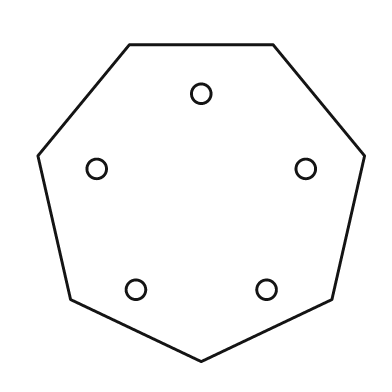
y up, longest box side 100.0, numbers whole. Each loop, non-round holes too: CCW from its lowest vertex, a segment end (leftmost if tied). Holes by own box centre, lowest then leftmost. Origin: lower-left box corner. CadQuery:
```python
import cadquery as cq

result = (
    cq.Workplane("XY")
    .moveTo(50.0, 0.0)
    .lineTo(90.0, 19.0)
    .lineTo(100.0, 63.0)
    .lineTo(72.0, 97.0)
    .lineTo(28.0, 97.0)
    .lineTo(0.0, 63.0)
    .lineTo(10.0, 19.0)
    .close()
    .moveTo(30.0, 22.0)
    .circle(3.0)
    .moveTo(70.0, 22.0)
    .circle(3.0)
    .moveTo(18.0, 59.0)
    .circle(3.0)
    .moveTo(82.0, 59.0)
    .circle(3.0)
    .moveTo(50.0, 82.0)
    .circle(3.0)
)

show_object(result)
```